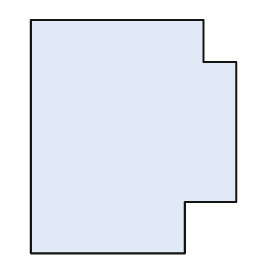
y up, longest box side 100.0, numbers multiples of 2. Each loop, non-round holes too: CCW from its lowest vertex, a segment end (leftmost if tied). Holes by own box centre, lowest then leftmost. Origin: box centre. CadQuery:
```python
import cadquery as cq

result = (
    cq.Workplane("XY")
    .moveTo(-44.0, -50.0)
    .lineTo(22.0, -50.0)
    .lineTo(22.0, -28.0)
    .lineTo(44.0, -28.0)
    .lineTo(44.0, 32.0)
    .lineTo(30.0, 32.0)
    .lineTo(30.0, 50.0)
    .lineTo(-44.0, 50.0)
    .close()
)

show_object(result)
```